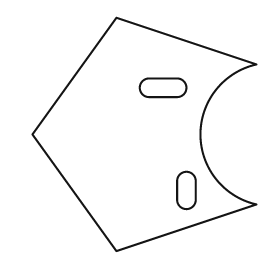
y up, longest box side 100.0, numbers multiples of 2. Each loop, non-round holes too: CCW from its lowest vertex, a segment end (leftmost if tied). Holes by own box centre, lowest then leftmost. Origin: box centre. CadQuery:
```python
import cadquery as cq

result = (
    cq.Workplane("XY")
    .moveTo(-12.0, -50.0)
    .lineTo(48.0, -30.0)
    .threePointArc((24.0, 0.0), (48.0, 30.0))
    .lineTo(-12.0, 50.0)
    .lineTo(-48.0, 0.0)
    .close()
    .moveTo(14.0, -28.0)
    .threePointArc((18.0, -32.0), (22.0, -28.0))
    .lineTo(22.0, -20.0)
    .threePointArc((18.0, -16.0), (14.0, -20.0))
    .close()
    .moveTo(2.0, 16.0)
    .lineTo(14.0, 16.0)
    .threePointArc((18.0, 20.0), (14.0, 24.0))
    .lineTo(2.0, 24.0)
    .threePointArc((-2.0, 20.0), (2.0, 16.0))
    .close()
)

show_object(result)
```